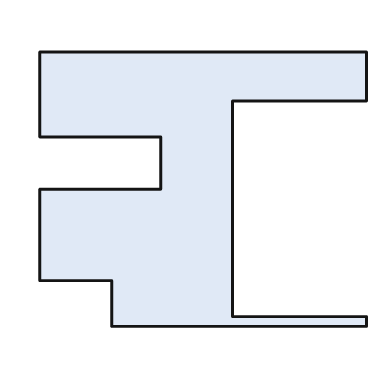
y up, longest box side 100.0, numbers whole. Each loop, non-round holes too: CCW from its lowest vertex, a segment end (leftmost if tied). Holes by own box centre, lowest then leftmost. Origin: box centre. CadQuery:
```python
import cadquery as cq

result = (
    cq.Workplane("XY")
    .moveTo(-28.0, -42.0)
    .lineTo(50.0, -42.0)
    .lineTo(50.0, -39.0)
    .lineTo(9.0, -39.0)
    .lineTo(9.0, 27.0)
    .lineTo(50.0, 27.0)
    .lineTo(50.0, 42.0)
    .lineTo(-50.0, 42.0)
    .lineTo(-50.0, 16.0)
    .lineTo(-13.0, 16.0)
    .lineTo(-13.0, 0.0)
    .lineTo(-50.0, 0.0)
    .lineTo(-50.0, -28.0)
    .lineTo(-28.0, -28.0)
    .close()
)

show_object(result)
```